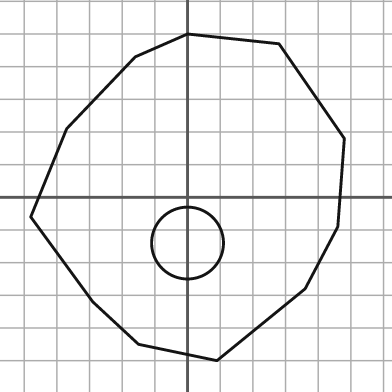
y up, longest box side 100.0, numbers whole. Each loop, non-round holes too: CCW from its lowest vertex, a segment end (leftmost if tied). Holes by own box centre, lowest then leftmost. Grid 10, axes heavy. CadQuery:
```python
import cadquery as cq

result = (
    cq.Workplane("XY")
    .moveTo(9.0, -50.0)
    .lineTo(36.0, -28.0)
    .lineTo(46.0, -9.0)
    .lineTo(48.0, 18.0)
    .lineTo(28.0, 47.0)
    .lineTo(0.0, 50.0)
    .lineTo(-16.0, 43.0)
    .lineTo(-37.0, 21.0)
    .lineTo(-48.0, -6.0)
    .lineTo(-29.0, -32.0)
    .lineTo(-15.0, -45.0)
    .close()
    .moveTo(0.0, -14.0)
    .circle(11.0)
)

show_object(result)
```